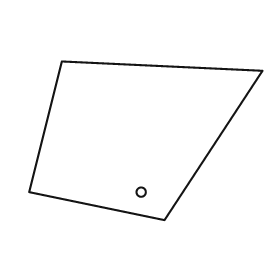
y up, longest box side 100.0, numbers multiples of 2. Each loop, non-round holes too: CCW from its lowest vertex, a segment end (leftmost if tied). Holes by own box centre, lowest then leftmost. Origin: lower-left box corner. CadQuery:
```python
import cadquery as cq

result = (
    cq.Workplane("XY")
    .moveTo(58.0, 0.0)
    .lineTo(100.0, 64.0)
    .lineTo(14.0, 68.0)
    .lineTo(0.0, 12.0)
    .close()
    .moveTo(48.0, 12.0)
    .circle(2.0)
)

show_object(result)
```